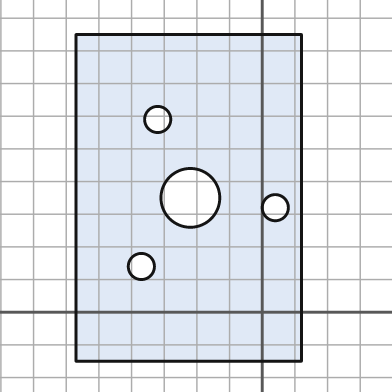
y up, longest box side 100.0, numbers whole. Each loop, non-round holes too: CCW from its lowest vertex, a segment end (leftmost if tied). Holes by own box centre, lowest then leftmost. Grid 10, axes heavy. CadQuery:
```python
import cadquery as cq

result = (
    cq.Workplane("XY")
    .moveTo(-57.0, -15.0)
    .lineTo(12.0, -15.0)
    .lineTo(12.0, 85.0)
    .lineTo(-57.0, 85.0)
    .close()
    .moveTo(-37.0, 14.0)
    .circle(4.0)
    .moveTo(4.0, 32.0)
    .circle(4.0)
    .moveTo(-22.0, 35.0)
    .circle(9.0)
    .moveTo(-32.0, 59.0)
    .circle(4.0)
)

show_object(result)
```